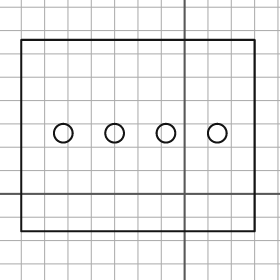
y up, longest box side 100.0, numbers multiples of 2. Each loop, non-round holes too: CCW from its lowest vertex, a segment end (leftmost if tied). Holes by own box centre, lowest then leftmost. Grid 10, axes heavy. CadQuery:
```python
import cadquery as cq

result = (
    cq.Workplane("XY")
    .moveTo(-70.0, -16.0)
    .lineTo(30.0, -16.0)
    .lineTo(30.0, 66.0)
    .lineTo(-70.0, 66.0)
    .close()
    .moveTo(-52.0, 26.0)
    .circle(4.0)
    .moveTo(-30.0, 26.0)
    .circle(4.0)
    .moveTo(-8.0, 26.0)
    .circle(4.0)
    .moveTo(14.0, 26.0)
    .circle(4.0)
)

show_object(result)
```